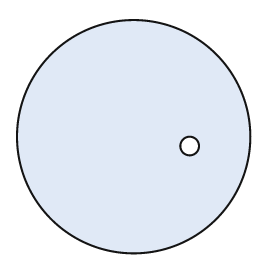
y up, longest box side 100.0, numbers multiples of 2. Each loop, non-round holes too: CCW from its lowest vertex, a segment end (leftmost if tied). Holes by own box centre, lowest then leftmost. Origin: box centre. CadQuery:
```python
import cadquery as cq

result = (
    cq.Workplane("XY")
    .moveTo(0.0, 0.0)
    .circle(50.0)
    .moveTo(24.0, -4.0)
    .circle(4.0)
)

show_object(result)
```